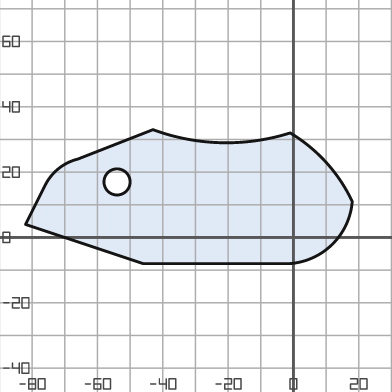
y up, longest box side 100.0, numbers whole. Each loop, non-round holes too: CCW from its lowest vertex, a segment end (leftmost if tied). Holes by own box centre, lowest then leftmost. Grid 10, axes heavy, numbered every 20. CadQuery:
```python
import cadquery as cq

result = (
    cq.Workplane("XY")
    .moveTo(-46.0, -8.0)
    .lineTo(-1.0, -8.0)
    .threePointArc((12.0, -2.0), (18.0, 11.0))
    .threePointArc((10.0, 23.0), (-1.0, 32.0))
    .threePointArc((-22.0, 29.0), (-43.0, 33.0))
    .lineTo(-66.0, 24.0)
    .threePointArc((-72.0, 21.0), (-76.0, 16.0))
    .lineTo(-82.0, 4.0)
    .close()
    .moveTo(-54.0, 17.0)
    .circle(4.0)
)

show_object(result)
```